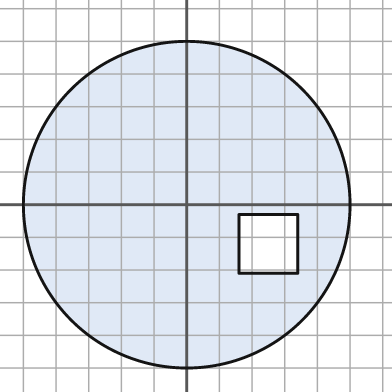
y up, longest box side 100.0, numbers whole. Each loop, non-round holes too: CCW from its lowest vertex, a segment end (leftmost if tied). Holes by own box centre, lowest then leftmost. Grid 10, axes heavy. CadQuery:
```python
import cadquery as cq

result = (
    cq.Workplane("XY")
    .moveTo(0.0, 0.0)
    .circle(50.0)
    .moveTo(16.0, -21.0)
    .lineTo(34.0, -21.0)
    .lineTo(34.0, -3.0)
    .lineTo(16.0, -3.0)
    .close()
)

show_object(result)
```